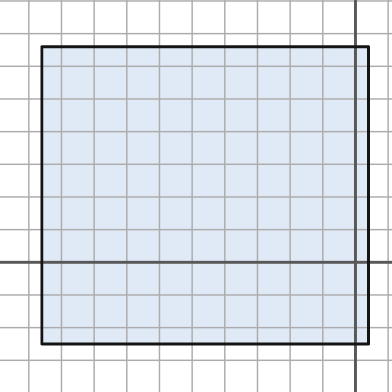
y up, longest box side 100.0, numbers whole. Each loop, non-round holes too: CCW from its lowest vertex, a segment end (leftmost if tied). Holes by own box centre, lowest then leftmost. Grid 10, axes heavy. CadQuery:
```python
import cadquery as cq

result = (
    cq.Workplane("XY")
    .moveTo(-96.0, -25.0)
    .lineTo(4.0, -25.0)
    .lineTo(4.0, 66.0)
    .lineTo(-96.0, 66.0)
    .close()
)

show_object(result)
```